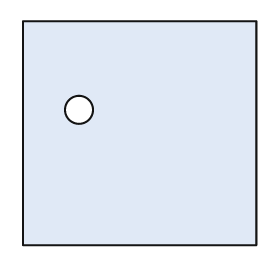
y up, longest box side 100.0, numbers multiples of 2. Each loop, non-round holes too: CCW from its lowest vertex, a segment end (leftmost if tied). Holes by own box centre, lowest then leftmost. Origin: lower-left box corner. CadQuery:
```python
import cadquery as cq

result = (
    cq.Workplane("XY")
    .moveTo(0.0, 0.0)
    .lineTo(100.0, 0.0)
    .lineTo(100.0, 96.0)
    .lineTo(0.0, 96.0)
    .close()
    .moveTo(24.0, 58.0)
    .circle(6.0)
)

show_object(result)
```